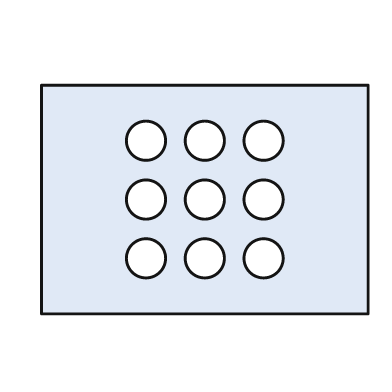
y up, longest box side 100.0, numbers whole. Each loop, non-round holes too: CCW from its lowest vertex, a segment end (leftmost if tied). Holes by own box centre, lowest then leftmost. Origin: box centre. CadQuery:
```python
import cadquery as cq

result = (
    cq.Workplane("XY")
    .moveTo(-50.0, -35.0)
    .lineTo(50.0, -35.0)
    .lineTo(50.0, 35.0)
    .lineTo(-50.0, 35.0)
    .close()
    .moveTo(-18.0, -18.0)
    .circle(6.0)
    .moveTo(0.0, -18.0)
    .circle(6.0)
    .moveTo(18.0, -18.0)
    .circle(6.0)
    .moveTo(-18.0, 0.0)
    .circle(6.0)
    .moveTo(0.0, 0.0)
    .circle(6.0)
    .moveTo(18.0, 0.0)
    .circle(6.0)
    .moveTo(-18.0, 18.0)
    .circle(6.0)
    .moveTo(0.0, 18.0)
    .circle(6.0)
    .moveTo(18.0, 18.0)
    .circle(6.0)
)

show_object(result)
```